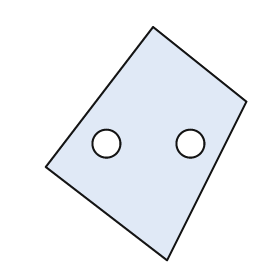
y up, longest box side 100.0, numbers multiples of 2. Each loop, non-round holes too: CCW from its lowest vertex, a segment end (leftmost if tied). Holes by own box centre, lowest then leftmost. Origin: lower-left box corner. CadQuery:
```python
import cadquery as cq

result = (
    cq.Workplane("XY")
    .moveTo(52.0, 0.0)
    .lineTo(86.0, 68.0)
    .lineTo(46.0, 100.0)
    .lineTo(0.0, 40.0)
    .close()
    .moveTo(26.0, 50.0)
    .circle(6.0)
    .moveTo(62.0, 50.0)
    .circle(6.0)
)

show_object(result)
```